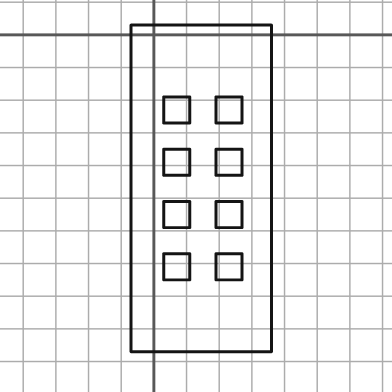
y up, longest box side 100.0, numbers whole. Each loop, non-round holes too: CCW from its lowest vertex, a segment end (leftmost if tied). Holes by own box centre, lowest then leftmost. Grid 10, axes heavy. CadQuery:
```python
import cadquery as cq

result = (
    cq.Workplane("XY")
    .moveTo(-7.0, -97.0)
    .lineTo(36.0, -97.0)
    .lineTo(36.0, 3.0)
    .lineTo(-7.0, 3.0)
    .close()
    .moveTo(3.0, -75.0)
    .lineTo(11.0, -75.0)
    .lineTo(11.0, -67.0)
    .lineTo(3.0, -67.0)
    .close()
    .moveTo(19.0, -75.0)
    .lineTo(27.0, -75.0)
    .lineTo(27.0, -67.0)
    .lineTo(19.0, -67.0)
    .close()
    .moveTo(3.0, -59.0)
    .lineTo(11.0, -59.0)
    .lineTo(11.0, -51.0)
    .lineTo(3.0, -51.0)
    .close()
    .moveTo(19.0, -59.0)
    .lineTo(27.0, -59.0)
    .lineTo(27.0, -51.0)
    .lineTo(19.0, -51.0)
    .close()
    .moveTo(3.0, -43.0)
    .lineTo(11.0, -43.0)
    .lineTo(11.0, -35.0)
    .lineTo(3.0, -35.0)
    .close()
    .moveTo(19.0, -43.0)
    .lineTo(27.0, -43.0)
    .lineTo(27.0, -35.0)
    .lineTo(19.0, -35.0)
    .close()
    .moveTo(3.0, -27.0)
    .lineTo(11.0, -27.0)
    .lineTo(11.0, -19.0)
    .lineTo(3.0, -19.0)
    .close()
    .moveTo(19.0, -27.0)
    .lineTo(27.0, -27.0)
    .lineTo(27.0, -19.0)
    .lineTo(19.0, -19.0)
    .close()
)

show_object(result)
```